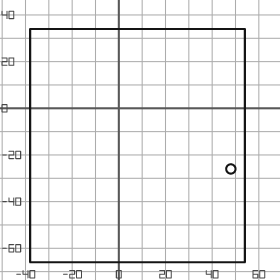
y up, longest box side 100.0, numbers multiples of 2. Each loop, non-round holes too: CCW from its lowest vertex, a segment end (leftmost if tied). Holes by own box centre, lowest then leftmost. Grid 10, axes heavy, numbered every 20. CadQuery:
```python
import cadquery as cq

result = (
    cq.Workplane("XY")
    .moveTo(-38.0, -66.0)
    .lineTo(54.0, -66.0)
    .lineTo(54.0, 34.0)
    .lineTo(-38.0, 34.0)
    .close()
    .moveTo(48.0, -26.0)
    .circle(2.0)
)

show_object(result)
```